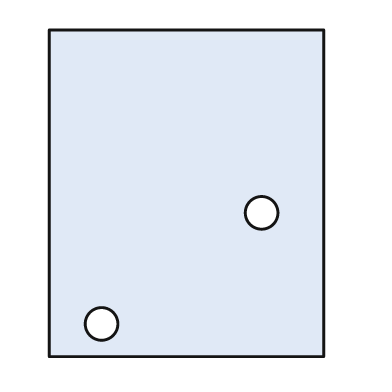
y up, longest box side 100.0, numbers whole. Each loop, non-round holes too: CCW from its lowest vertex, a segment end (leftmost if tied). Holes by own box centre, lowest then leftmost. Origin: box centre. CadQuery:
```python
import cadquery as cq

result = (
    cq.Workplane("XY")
    .moveTo(-42.0, -50.0)
    .lineTo(42.0, -50.0)
    .lineTo(42.0, 50.0)
    .lineTo(-42.0, 50.0)
    .close()
    .moveTo(-26.0, -40.0)
    .circle(5.0)
    .moveTo(23.0, -6.0)
    .circle(5.0)
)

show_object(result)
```